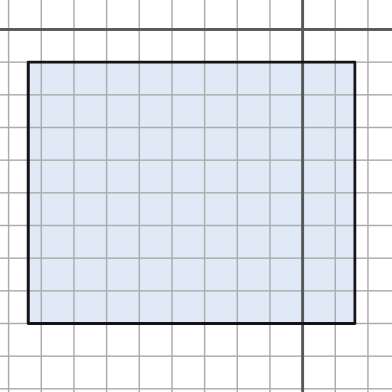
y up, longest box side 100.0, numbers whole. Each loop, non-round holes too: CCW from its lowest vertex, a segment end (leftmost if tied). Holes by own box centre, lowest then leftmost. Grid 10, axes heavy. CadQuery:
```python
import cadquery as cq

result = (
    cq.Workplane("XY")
    .moveTo(-84.0, -90.0)
    .lineTo(16.0, -90.0)
    .lineTo(16.0, -10.0)
    .lineTo(-84.0, -10.0)
    .close()
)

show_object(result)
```